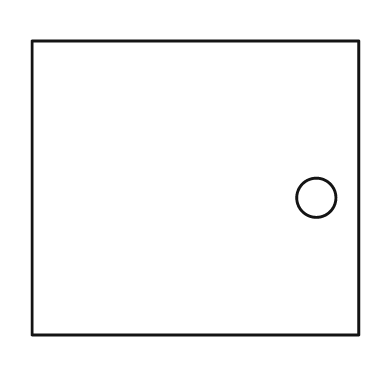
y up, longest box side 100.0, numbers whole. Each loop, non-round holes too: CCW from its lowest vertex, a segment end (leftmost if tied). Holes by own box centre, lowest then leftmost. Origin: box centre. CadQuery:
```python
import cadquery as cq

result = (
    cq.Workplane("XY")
    .moveTo(-50.0, -45.0)
    .lineTo(50.0, -45.0)
    .lineTo(50.0, 45.0)
    .lineTo(-50.0, 45.0)
    .close()
    .moveTo(37.0, -3.0)
    .circle(6.0)
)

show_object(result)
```